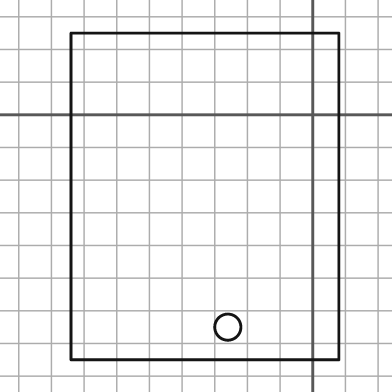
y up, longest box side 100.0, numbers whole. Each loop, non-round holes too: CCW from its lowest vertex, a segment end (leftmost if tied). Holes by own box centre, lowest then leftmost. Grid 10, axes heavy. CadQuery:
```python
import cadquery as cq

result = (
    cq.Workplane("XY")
    .moveTo(-74.0, -75.0)
    .lineTo(8.0, -75.0)
    .lineTo(8.0, 25.0)
    .lineTo(-74.0, 25.0)
    .close()
    .moveTo(-26.0, -65.0)
    .circle(4.0)
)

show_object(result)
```